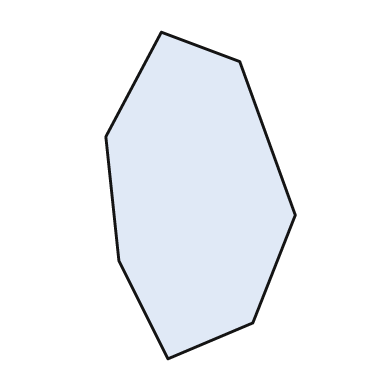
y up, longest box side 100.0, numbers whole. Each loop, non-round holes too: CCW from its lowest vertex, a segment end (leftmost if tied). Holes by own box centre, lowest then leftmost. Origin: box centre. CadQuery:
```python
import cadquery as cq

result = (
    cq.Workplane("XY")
    .moveTo(-10.0, -50.0)
    .lineTo(16.0, -39.0)
    .lineTo(29.0, -6.0)
    .lineTo(12.0, 41.0)
    .lineTo(-12.0, 50.0)
    .lineTo(-29.0, 18.0)
    .lineTo(-25.0, -20.0)
    .close()
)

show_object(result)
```